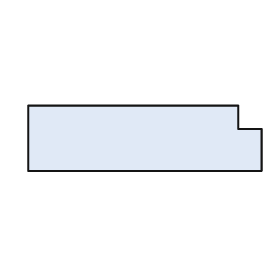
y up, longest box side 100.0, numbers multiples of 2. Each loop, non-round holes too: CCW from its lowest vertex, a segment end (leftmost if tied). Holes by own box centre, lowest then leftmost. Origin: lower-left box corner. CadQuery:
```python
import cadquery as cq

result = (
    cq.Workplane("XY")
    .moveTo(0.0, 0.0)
    .lineTo(100.0, 0.0)
    .lineTo(100.0, 18.0)
    .lineTo(90.0, 18.0)
    .lineTo(90.0, 28.0)
    .lineTo(0.0, 28.0)
    .close()
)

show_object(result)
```